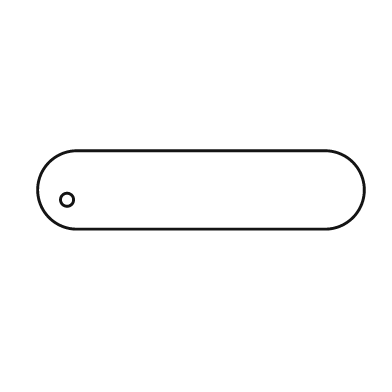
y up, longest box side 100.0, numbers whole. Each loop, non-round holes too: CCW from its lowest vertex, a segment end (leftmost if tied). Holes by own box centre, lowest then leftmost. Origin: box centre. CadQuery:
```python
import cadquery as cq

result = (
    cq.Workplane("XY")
    .moveTo(-38.0, -12.0)
    .lineTo(38.0, -12.0)
    .threePointArc((50.0, 0.0), (38.0, 12.0))
    .lineTo(-38.0, 12.0)
    .threePointArc((-50.0, 0.0), (-38.0, -12.0))
    .close()
    .moveTo(-41.0, -3.0)
    .circle(2.0)
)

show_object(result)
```